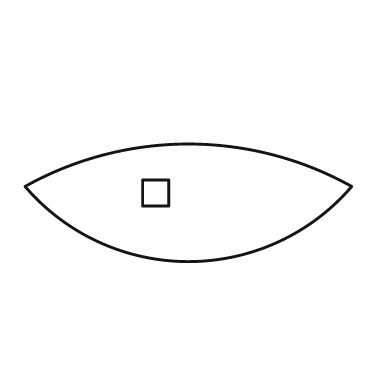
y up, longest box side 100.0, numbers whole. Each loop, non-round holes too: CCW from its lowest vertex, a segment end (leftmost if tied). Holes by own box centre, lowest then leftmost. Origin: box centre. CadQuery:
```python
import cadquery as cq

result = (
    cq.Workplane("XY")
    .moveTo(-50.0, 5.0)
    .threePointArc((0.0, -18.0), (50.0, 5.0))
    .threePointArc((0.0, 18.0), (-50.0, 5.0))
    .close()
    .moveTo(-14.0, -1.0)
    .lineTo(-6.0, -1.0)
    .lineTo(-6.0, 7.0)
    .lineTo(-14.0, 7.0)
    .close()
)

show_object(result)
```